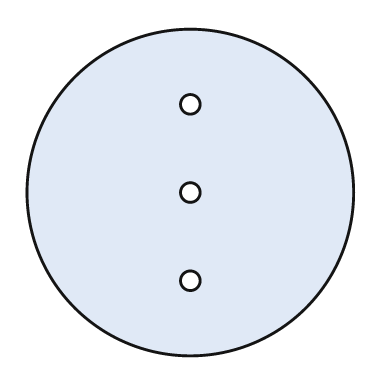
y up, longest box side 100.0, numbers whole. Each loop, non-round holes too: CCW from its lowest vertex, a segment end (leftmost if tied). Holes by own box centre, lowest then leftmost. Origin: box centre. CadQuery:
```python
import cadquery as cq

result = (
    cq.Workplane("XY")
    .moveTo(0.0, 0.0)
    .circle(50.0)
    .moveTo(0.0, -27.0)
    .circle(3.0)
    .moveTo(0.0, 0.0)
    .circle(3.0)
    .moveTo(0.0, 27.0)
    .circle(3.0)
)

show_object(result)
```